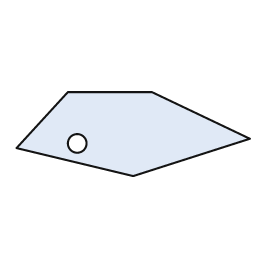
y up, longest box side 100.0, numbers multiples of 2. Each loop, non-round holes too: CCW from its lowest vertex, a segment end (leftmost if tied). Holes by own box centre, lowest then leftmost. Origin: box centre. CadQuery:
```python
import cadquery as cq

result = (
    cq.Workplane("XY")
    .moveTo(0.0, -18.0)
    .lineTo(50.0, -2.0)
    .lineTo(8.0, 18.0)
    .lineTo(-28.0, 18.0)
    .lineTo(-50.0, -6.0)
    .close()
    .moveTo(-24.0, -4.0)
    .circle(4.0)
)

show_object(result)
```